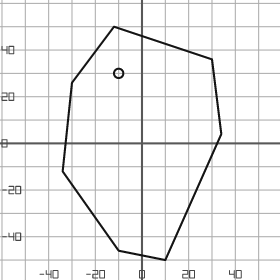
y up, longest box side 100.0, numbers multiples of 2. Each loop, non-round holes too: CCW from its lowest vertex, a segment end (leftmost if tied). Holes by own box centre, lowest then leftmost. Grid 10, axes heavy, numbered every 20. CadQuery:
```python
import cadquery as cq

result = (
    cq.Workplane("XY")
    .moveTo(10.0, -50.0)
    .lineTo(34.0, 4.0)
    .lineTo(30.0, 36.0)
    .lineTo(-12.0, 50.0)
    .lineTo(-30.0, 26.0)
    .lineTo(-34.0, -12.0)
    .lineTo(-10.0, -46.0)
    .close()
    .moveTo(-10.0, 30.0)
    .circle(2.0)
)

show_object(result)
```